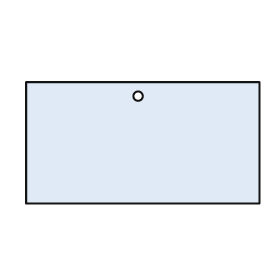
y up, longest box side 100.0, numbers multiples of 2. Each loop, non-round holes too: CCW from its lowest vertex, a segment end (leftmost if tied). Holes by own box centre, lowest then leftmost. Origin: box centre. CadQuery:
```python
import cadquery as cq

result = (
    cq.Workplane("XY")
    .moveTo(-50.0, -26.0)
    .lineTo(50.0, -26.0)
    .lineTo(50.0, 26.0)
    .lineTo(-50.0, 26.0)
    .close()
    .moveTo(-2.0, 20.0)
    .circle(2.0)
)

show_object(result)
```